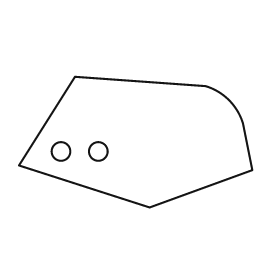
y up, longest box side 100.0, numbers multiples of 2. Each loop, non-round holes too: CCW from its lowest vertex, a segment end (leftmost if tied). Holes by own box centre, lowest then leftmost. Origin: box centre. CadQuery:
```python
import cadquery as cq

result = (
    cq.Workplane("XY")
    .moveTo(6.0, -28.0)
    .lineTo(50.0, -12.0)
    .lineTo(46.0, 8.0)
    .threePointArc((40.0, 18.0), (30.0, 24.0))
    .lineTo(-26.0, 28.0)
    .lineTo(-50.0, -10.0)
    .close()
    .moveTo(-32.0, -4.0)
    .circle(4.0)
    .moveTo(-16.0, -4.0)
    .circle(4.0)
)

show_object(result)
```